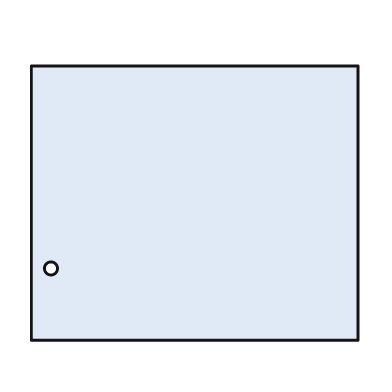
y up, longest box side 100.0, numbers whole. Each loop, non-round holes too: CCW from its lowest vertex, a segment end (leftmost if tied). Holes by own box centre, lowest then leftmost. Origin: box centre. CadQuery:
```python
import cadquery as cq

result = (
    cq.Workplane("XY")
    .moveTo(-50.0, -42.0)
    .lineTo(50.0, -42.0)
    .lineTo(50.0, 42.0)
    .lineTo(-50.0, 42.0)
    .close()
    .moveTo(-44.0, -20.0)
    .circle(2.0)
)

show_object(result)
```